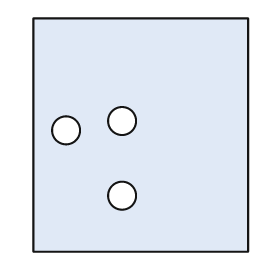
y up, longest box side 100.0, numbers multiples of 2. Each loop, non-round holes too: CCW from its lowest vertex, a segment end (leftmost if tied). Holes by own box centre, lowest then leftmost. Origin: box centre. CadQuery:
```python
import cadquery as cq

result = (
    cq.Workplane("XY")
    .moveTo(-46.0, -50.0)
    .lineTo(46.0, -50.0)
    .lineTo(46.0, 50.0)
    .lineTo(-46.0, 50.0)
    .close()
    .moveTo(-8.0, -26.0)
    .circle(6.0)
    .moveTo(-32.0, 2.0)
    .circle(6.0)
    .moveTo(-8.0, 6.0)
    .circle(6.0)
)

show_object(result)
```